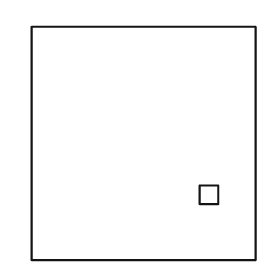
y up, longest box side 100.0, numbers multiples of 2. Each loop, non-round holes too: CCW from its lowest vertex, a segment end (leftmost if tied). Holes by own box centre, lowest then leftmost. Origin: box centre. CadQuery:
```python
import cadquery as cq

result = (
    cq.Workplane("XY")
    .moveTo(-48.0, -50.0)
    .lineTo(48.0, -50.0)
    .lineTo(48.0, 50.0)
    .lineTo(-48.0, 50.0)
    .close()
    .moveTo(24.0, -26.0)
    .lineTo(32.0, -26.0)
    .lineTo(32.0, -18.0)
    .lineTo(24.0, -18.0)
    .close()
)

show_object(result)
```